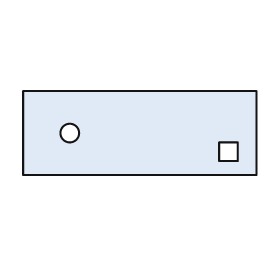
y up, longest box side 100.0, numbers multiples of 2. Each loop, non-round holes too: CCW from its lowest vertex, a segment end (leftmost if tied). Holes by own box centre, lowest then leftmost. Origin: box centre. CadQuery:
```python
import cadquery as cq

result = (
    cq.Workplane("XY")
    .moveTo(-50.0, -18.0)
    .lineTo(50.0, -18.0)
    .lineTo(50.0, 18.0)
    .lineTo(-50.0, 18.0)
    .close()
    .moveTo(34.0, -12.0)
    .lineTo(42.0, -12.0)
    .lineTo(42.0, -4.0)
    .lineTo(34.0, -4.0)
    .close()
    .moveTo(-30.0, 0.0)
    .circle(4.0)
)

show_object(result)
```